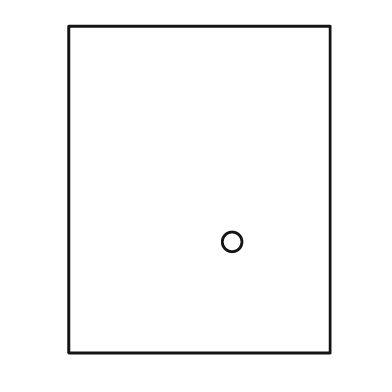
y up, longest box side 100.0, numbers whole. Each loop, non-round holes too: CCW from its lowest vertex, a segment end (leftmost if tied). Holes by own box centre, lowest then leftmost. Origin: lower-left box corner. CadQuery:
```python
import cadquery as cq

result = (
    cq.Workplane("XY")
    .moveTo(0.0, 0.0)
    .lineTo(80.0, 0.0)
    .lineTo(80.0, 100.0)
    .lineTo(0.0, 100.0)
    .close()
    .moveTo(50.0, 34.0)
    .circle(3.0)
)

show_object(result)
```